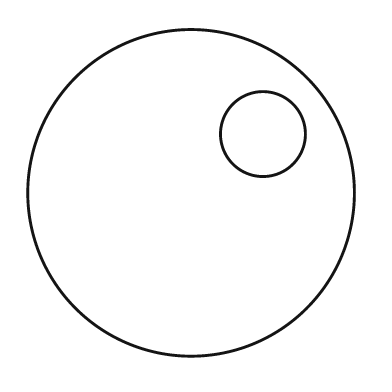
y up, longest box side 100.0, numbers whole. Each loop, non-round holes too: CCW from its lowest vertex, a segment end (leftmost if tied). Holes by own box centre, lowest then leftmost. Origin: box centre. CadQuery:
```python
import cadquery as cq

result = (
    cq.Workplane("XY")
    .moveTo(0.0, 0.0)
    .circle(50.0)
    .moveTo(22.0, 18.0)
    .circle(13.0)
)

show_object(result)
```